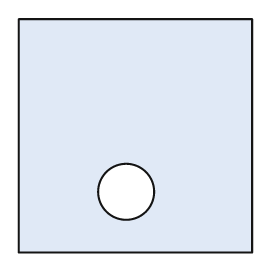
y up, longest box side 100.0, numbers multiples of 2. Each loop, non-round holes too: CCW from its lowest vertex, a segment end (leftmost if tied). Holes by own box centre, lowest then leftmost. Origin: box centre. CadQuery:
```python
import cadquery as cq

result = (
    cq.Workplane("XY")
    .moveTo(-50.0, -50.0)
    .lineTo(50.0, -50.0)
    .lineTo(50.0, 50.0)
    .lineTo(-50.0, 50.0)
    .close()
    .moveTo(-4.0, -24.0)
    .circle(12.0)
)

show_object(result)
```